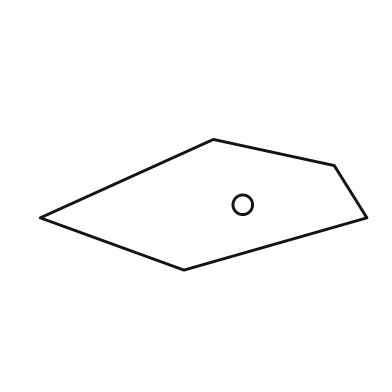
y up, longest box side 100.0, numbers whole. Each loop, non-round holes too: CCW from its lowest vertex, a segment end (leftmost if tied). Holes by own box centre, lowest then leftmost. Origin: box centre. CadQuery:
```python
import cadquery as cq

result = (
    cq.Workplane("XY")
    .moveTo(-6.0, -20.0)
    .lineTo(50.0, -4.0)
    .lineTo(40.0, 12.0)
    .lineTo(3.0, 20.0)
    .lineTo(-50.0, -4.0)
    .close()
    .moveTo(12.0, 0.0)
    .circle(3.0)
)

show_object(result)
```